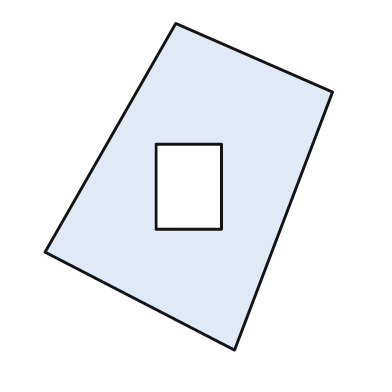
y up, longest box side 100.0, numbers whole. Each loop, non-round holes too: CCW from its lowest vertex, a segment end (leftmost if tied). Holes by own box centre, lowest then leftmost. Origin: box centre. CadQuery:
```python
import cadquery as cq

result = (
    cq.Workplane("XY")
    .moveTo(14.0, -50.0)
    .lineTo(44.0, 29.0)
    .lineTo(-4.0, 50.0)
    .lineTo(-44.0, -20.0)
    .close()
    .moveTo(-10.0, -13.0)
    .lineTo(10.0, -13.0)
    .lineTo(10.0, 13.0)
    .lineTo(-10.0, 13.0)
    .close()
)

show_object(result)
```